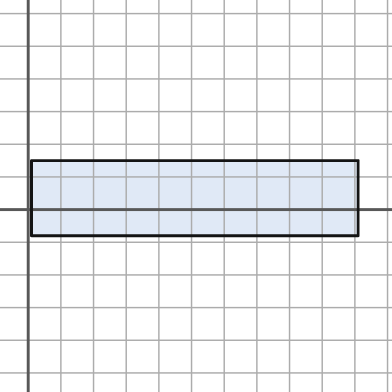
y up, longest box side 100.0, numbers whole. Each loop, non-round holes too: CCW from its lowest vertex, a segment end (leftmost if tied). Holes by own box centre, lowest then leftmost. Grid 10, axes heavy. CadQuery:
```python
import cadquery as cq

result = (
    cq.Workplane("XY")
    .moveTo(1.0, -8.0)
    .lineTo(101.0, -8.0)
    .lineTo(101.0, 15.0)
    .lineTo(1.0, 15.0)
    .close()
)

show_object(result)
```